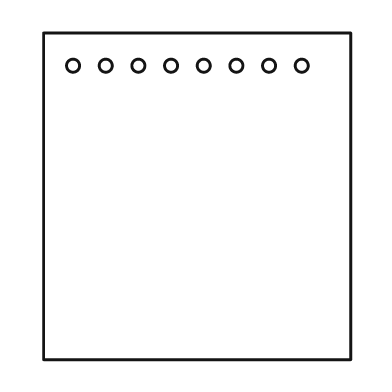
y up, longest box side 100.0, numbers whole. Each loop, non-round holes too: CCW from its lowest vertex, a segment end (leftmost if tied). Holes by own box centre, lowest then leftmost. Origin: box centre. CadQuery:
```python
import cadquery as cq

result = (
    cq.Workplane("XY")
    .moveTo(-47.0, -50.0)
    .lineTo(47.0, -50.0)
    .lineTo(47.0, 50.0)
    .lineTo(-47.0, 50.0)
    .close()
    .moveTo(-38.0, 40.0)
    .circle(2.0)
    .moveTo(-28.0, 40.0)
    .circle(2.0)
    .moveTo(-18.0, 40.0)
    .circle(2.0)
    .moveTo(-8.0, 40.0)
    .circle(2.0)
    .moveTo(2.0, 40.0)
    .circle(2.0)
    .moveTo(12.0, 40.0)
    .circle(2.0)
    .moveTo(22.0, 40.0)
    .circle(2.0)
    .moveTo(32.0, 40.0)
    .circle(2.0)
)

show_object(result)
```